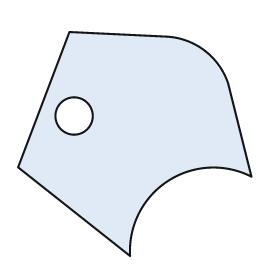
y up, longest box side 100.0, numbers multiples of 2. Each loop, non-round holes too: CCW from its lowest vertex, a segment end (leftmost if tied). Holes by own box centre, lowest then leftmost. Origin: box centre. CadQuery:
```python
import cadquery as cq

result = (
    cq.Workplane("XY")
    .moveTo(-2.0, -48.0)
    .threePointArc((14.0, -16.0), (50.0, -14.0))
    .lineTo(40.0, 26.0)
    .threePointArc((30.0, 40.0), (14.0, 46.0))
    .lineTo(-28.0, 48.0)
    .lineTo(-50.0, -10.0)
    .close()
    .moveTo(-26.0, 12.0)
    .circle(8.0)
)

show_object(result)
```